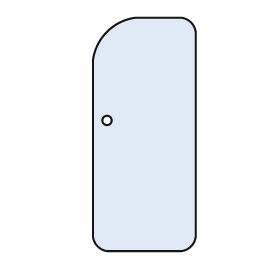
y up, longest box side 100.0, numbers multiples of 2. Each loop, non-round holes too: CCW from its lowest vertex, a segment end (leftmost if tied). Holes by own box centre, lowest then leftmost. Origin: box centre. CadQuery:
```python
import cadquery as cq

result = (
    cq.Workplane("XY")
    .moveTo(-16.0, -50.0)
    .lineTo(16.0, -50.0)
    .threePointArc((20.0, -48.0), (22.0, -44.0))
    .lineTo(22.0, 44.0)
    .threePointArc((20.0, 48.0), (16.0, 50.0))
    .lineTo(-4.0, 50.0)
    .threePointArc((-16.0, 44.0), (-22.0, 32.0))
    .lineTo(-22.0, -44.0)
    .threePointArc((-20.0, -48.0), (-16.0, -50.0))
    .close()
    .moveTo(-16.0, 6.0)
    .circle(2.0)
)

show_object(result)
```